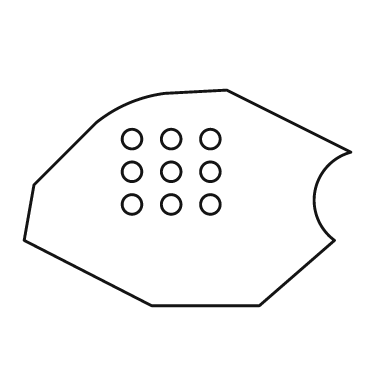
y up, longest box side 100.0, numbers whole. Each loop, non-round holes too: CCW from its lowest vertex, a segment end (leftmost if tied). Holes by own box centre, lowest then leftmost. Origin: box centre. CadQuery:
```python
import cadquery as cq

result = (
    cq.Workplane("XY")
    .moveTo(-11.0, -33.0)
    .lineTo(22.0, -33.0)
    .lineTo(45.0, -13.0)
    .threePointArc((39.0, 2.0), (50.0, 14.0))
    .lineTo(12.0, 33.0)
    .lineTo(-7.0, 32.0)
    .threePointArc((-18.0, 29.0), (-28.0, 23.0))
    .lineTo(-47.0, 4.0)
    .lineTo(-50.0, -13.0)
    .close()
    .moveTo(-17.0, -2.0)
    .circle(3.0)
    .moveTo(-5.0, -2.0)
    .circle(3.0)
    .moveTo(7.0, -2.0)
    .circle(3.0)
    .moveTo(-17.0, 8.0)
    .circle(3.0)
    .moveTo(-5.0, 8.0)
    .circle(3.0)
    .moveTo(7.0, 8.0)
    .circle(3.0)
    .moveTo(-17.0, 18.0)
    .circle(3.0)
    .moveTo(-5.0, 18.0)
    .circle(3.0)
    .moveTo(7.0, 18.0)
    .circle(3.0)
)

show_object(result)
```